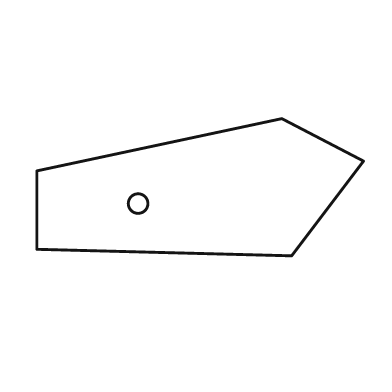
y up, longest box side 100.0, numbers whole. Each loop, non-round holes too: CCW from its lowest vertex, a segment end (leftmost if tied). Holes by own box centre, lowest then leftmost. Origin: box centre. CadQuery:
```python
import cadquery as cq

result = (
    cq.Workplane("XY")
    .moveTo(28.0, -21.0)
    .lineTo(50.0, 8.0)
    .lineTo(25.0, 21.0)
    .lineTo(-50.0, 5.0)
    .lineTo(-50.0, -19.0)
    .close()
    .moveTo(-19.0, -5.0)
    .circle(3.0)
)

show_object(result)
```